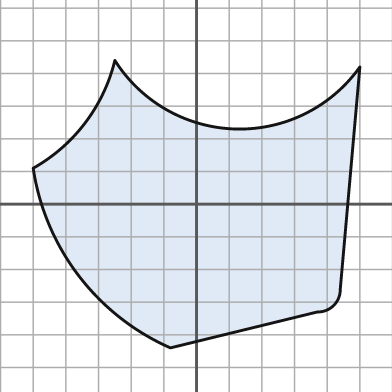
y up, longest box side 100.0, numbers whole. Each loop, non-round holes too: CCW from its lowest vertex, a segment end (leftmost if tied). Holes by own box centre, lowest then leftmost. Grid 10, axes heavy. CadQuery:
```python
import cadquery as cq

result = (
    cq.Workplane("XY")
    .moveTo(-8.0, -44.0)
    .lineTo(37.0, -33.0)
    .threePointArc((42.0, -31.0), (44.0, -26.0))
    .lineTo(50.0, 42.0)
    .threePointArc((12.0, 23.0), (-25.0, 44.0))
    .threePointArc((-34.0, 25.0), (-50.0, 11.0))
    .threePointArc((-36.0, -22.0), (-8.0, -44.0))
    .close()
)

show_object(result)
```